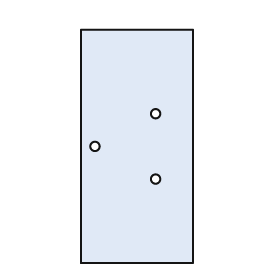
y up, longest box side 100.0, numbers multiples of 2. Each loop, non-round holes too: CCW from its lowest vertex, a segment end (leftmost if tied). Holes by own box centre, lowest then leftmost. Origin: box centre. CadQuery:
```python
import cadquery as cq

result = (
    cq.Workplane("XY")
    .moveTo(-24.0, -50.0)
    .lineTo(24.0, -50.0)
    .lineTo(24.0, 50.0)
    .lineTo(-24.0, 50.0)
    .close()
    .moveTo(8.0, -14.0)
    .circle(2.0)
    .moveTo(-18.0, 0.0)
    .circle(2.0)
    .moveTo(8.0, 14.0)
    .circle(2.0)
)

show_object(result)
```